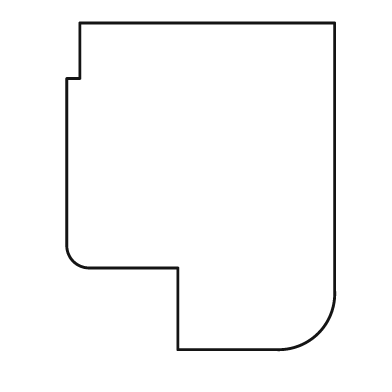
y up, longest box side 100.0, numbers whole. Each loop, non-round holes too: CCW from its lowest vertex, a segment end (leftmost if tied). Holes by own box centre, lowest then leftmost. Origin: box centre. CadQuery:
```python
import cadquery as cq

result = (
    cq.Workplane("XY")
    .moveTo(-7.0, -50.0)
    .lineTo(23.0, -50.0)
    .threePointArc((36.0, -45.0), (41.0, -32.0))
    .lineTo(41.0, 50.0)
    .lineTo(-37.0, 50.0)
    .lineTo(-37.0, 33.0)
    .lineTo(-41.0, 33.0)
    .lineTo(-41.0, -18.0)
    .threePointArc((-39.0, -23.0), (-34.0, -25.0))
    .lineTo(-7.0, -25.0)
    .close()
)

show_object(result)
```